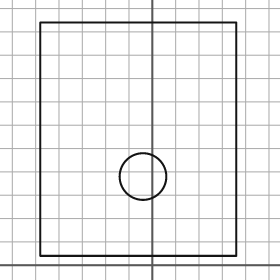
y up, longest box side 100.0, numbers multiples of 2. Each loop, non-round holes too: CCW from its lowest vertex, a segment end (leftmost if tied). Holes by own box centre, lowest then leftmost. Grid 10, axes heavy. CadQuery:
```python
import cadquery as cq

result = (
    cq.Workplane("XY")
    .moveTo(-48.0, 4.0)
    .lineTo(36.0, 4.0)
    .lineTo(36.0, 104.0)
    .lineTo(-48.0, 104.0)
    .close()
    .moveTo(-4.0, 38.0)
    .circle(10.0)
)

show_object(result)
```